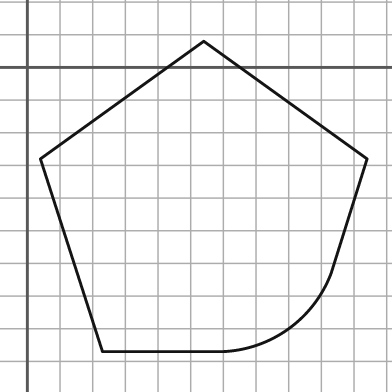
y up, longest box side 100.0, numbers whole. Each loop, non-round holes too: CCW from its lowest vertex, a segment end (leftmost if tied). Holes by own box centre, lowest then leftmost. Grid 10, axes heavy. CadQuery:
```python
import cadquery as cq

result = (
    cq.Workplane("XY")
    .moveTo(23.0, -87.0)
    .lineTo(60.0, -87.0)
    .threePointArc((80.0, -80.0), (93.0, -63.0))
    .lineTo(104.0, -28.0)
    .lineTo(54.0, 8.0)
    .lineTo(4.0, -28.0)
    .close()
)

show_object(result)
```